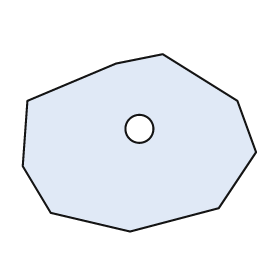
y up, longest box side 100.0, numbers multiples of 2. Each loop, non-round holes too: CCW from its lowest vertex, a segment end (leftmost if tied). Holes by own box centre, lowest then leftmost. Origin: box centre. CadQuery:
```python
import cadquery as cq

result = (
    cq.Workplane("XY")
    .moveTo(-4.0, -38.0)
    .lineTo(34.0, -28.0)
    .lineTo(50.0, -4.0)
    .lineTo(42.0, 18.0)
    .lineTo(10.0, 38.0)
    .lineTo(-10.0, 34.0)
    .lineTo(-48.0, 18.0)
    .lineTo(-50.0, -10.0)
    .lineTo(-38.0, -30.0)
    .close()
    .moveTo(0.0, 6.0)
    .circle(6.0)
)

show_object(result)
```